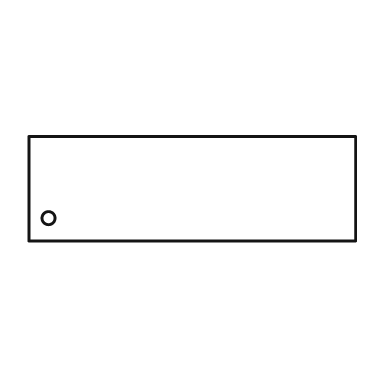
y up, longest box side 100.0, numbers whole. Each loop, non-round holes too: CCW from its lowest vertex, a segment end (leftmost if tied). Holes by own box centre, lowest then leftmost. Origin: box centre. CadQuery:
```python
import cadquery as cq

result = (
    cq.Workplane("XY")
    .moveTo(-50.0, -16.0)
    .lineTo(50.0, -16.0)
    .lineTo(50.0, 16.0)
    .lineTo(-50.0, 16.0)
    .close()
    .moveTo(-44.0, -9.0)
    .circle(2.0)
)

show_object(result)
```